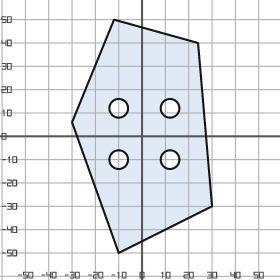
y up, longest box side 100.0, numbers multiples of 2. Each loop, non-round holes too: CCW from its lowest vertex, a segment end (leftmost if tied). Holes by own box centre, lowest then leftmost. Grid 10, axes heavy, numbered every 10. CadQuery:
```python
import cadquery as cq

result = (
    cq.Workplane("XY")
    .moveTo(-10.0, -50.0)
    .lineTo(30.0, -30.0)
    .lineTo(24.0, 40.0)
    .lineTo(-12.0, 50.0)
    .lineTo(-30.0, 6.0)
    .close()
    .moveTo(-10.0, -10.0)
    .circle(4.0)
    .moveTo(12.0, -10.0)
    .circle(4.0)
    .moveTo(-10.0, 12.0)
    .circle(4.0)
    .moveTo(12.0, 12.0)
    .circle(4.0)
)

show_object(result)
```